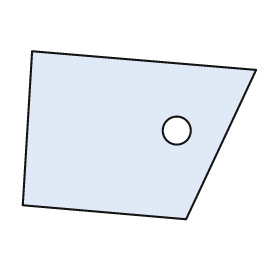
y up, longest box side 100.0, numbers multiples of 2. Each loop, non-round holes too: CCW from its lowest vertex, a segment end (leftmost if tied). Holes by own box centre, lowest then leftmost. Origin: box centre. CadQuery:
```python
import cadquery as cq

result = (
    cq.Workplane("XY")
    .moveTo(20.0, -36.0)
    .lineTo(50.0, 28.0)
    .lineTo(-46.0, 36.0)
    .lineTo(-50.0, -30.0)
    .close()
    .moveTo(16.0, 2.0)
    .circle(6.0)
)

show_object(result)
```